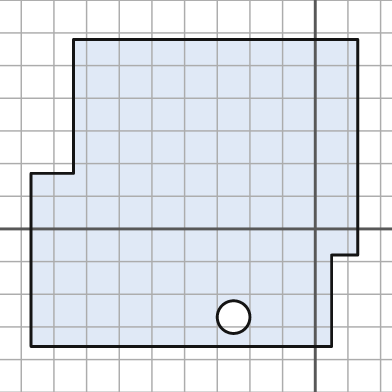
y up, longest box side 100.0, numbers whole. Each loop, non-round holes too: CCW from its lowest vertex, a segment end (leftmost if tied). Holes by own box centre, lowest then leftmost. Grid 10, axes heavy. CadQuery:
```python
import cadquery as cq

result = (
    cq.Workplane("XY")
    .moveTo(-87.0, -36.0)
    .lineTo(5.0, -36.0)
    .lineTo(5.0, -8.0)
    .lineTo(13.0, -8.0)
    .lineTo(13.0, 58.0)
    .lineTo(-74.0, 58.0)
    .lineTo(-74.0, 17.0)
    .lineTo(-87.0, 17.0)
    .close()
    .moveTo(-25.0, -27.0)
    .circle(5.0)
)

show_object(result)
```